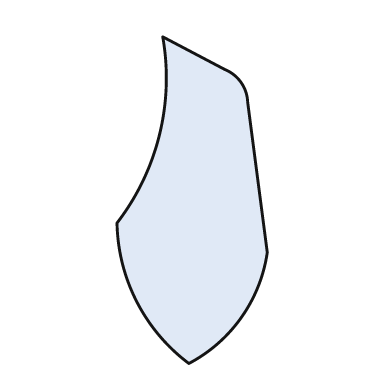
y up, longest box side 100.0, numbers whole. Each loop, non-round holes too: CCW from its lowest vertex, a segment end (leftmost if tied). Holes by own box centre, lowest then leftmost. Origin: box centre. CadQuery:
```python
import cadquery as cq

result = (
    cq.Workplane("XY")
    .moveTo(-1.0, -50.0)
    .threePointArc((15.0, -36.0), (23.0, -16.0))
    .lineTo(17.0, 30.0)
    .threePointArc((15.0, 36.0), (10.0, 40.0))
    .lineTo(-9.0, 50.0)
    .threePointArc((-10.0, 20.0), (-23.0, -7.0))
    .threePointArc((-17.0, -31.0), (-1.0, -50.0))
    .close()
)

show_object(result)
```